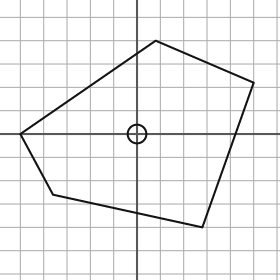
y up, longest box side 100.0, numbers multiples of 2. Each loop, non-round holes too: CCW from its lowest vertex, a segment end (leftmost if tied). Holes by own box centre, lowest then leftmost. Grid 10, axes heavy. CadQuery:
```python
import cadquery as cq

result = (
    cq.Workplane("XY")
    .moveTo(28.0, -40.0)
    .lineTo(50.0, 22.0)
    .lineTo(8.0, 40.0)
    .lineTo(-50.0, 0.0)
    .lineTo(-36.0, -26.0)
    .close()
    .moveTo(0.0, 0.0)
    .circle(4.0)
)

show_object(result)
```